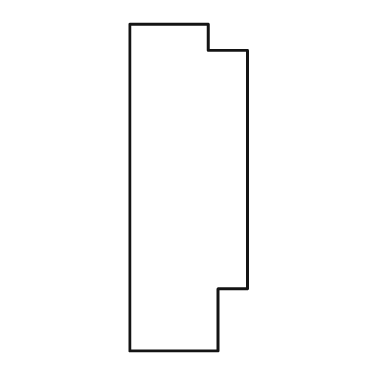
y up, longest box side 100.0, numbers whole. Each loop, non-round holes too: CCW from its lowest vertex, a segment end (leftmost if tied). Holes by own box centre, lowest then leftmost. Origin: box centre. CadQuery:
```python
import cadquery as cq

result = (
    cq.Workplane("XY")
    .moveTo(-18.0, -50.0)
    .lineTo(9.0, -50.0)
    .lineTo(9.0, -31.0)
    .lineTo(18.0, -31.0)
    .lineTo(18.0, 42.0)
    .lineTo(6.0, 42.0)
    .lineTo(6.0, 50.0)
    .lineTo(-18.0, 50.0)
    .close()
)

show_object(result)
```